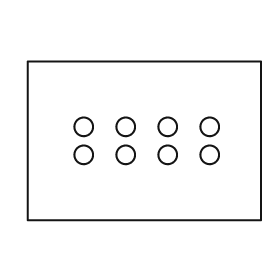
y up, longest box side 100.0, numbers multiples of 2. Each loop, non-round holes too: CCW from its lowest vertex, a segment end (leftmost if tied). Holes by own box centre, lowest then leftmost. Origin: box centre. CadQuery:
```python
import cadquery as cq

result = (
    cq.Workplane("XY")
    .moveTo(-50.0, -34.0)
    .lineTo(50.0, -34.0)
    .lineTo(50.0, 34.0)
    .lineTo(-50.0, 34.0)
    .close()
    .moveTo(-26.0, -6.0)
    .circle(4.0)
    .moveTo(-8.0, -6.0)
    .circle(4.0)
    .moveTo(10.0, -6.0)
    .circle(4.0)
    .moveTo(28.0, -6.0)
    .circle(4.0)
    .moveTo(-26.0, 6.0)
    .circle(4.0)
    .moveTo(-8.0, 6.0)
    .circle(4.0)
    .moveTo(10.0, 6.0)
    .circle(4.0)
    .moveTo(28.0, 6.0)
    .circle(4.0)
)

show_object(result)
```